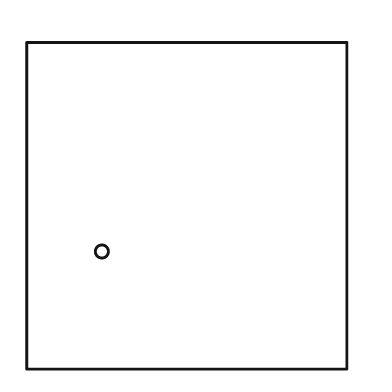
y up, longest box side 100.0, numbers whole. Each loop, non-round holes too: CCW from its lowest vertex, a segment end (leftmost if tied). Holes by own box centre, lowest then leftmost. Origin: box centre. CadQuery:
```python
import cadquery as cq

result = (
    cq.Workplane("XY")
    .moveTo(-49.0, -50.0)
    .lineTo(49.0, -50.0)
    .lineTo(49.0, 50.0)
    .lineTo(-49.0, 50.0)
    .close()
    .moveTo(-26.0, -14.0)
    .circle(2.0)
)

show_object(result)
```